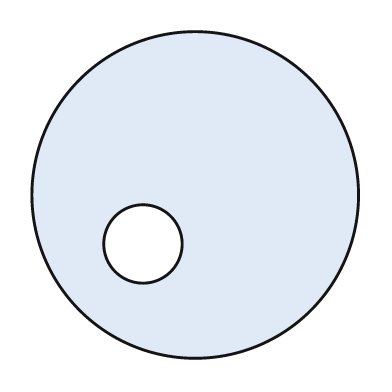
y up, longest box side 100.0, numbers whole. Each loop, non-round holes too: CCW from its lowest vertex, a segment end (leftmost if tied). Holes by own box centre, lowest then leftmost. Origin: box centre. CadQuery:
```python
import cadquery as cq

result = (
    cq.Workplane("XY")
    .moveTo(0.0, 0.0)
    .circle(50.0)
    .moveTo(-16.0, -15.0)
    .circle(12.0)
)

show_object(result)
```